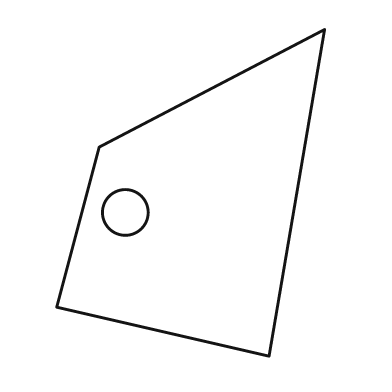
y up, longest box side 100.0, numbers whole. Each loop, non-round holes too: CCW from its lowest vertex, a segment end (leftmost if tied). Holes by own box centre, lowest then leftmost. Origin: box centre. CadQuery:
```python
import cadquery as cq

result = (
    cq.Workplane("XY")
    .moveTo(24.0, -50.0)
    .lineTo(41.0, 50.0)
    .lineTo(-28.0, 14.0)
    .lineTo(-41.0, -35.0)
    .close()
    .moveTo(-20.0, -6.0)
    .circle(7.0)
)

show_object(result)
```